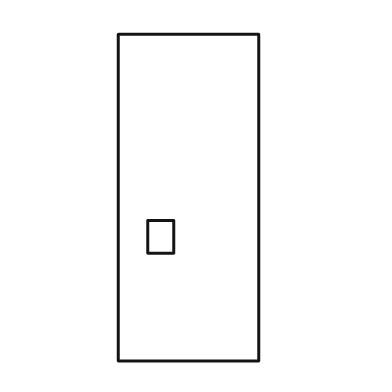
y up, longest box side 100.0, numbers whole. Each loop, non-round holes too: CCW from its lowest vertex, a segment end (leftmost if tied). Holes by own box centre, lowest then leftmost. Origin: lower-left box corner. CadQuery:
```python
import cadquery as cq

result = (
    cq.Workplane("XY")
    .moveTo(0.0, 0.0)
    .lineTo(43.0, 0.0)
    .lineTo(43.0, 100.0)
    .lineTo(0.0, 100.0)
    .close()
    .moveTo(9.0, 33.0)
    .lineTo(17.0, 33.0)
    .lineTo(17.0, 43.0)
    .lineTo(9.0, 43.0)
    .close()
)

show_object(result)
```